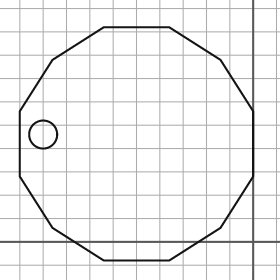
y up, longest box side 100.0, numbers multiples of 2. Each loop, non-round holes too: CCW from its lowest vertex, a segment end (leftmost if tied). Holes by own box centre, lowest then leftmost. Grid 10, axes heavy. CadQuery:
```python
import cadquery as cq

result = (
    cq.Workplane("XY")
    .moveTo(-64.0, -8.0)
    .lineTo(-36.0, -8.0)
    .lineTo(-14.0, 6.0)
    .lineTo(0.0, 28.0)
    .lineTo(0.0, 56.0)
    .lineTo(-14.0, 78.0)
    .lineTo(-36.0, 92.0)
    .lineTo(-64.0, 92.0)
    .lineTo(-86.0, 78.0)
    .lineTo(-100.0, 56.0)
    .lineTo(-100.0, 28.0)
    .lineTo(-86.0, 6.0)
    .close()
    .moveTo(-90.0, 46.0)
    .circle(6.0)
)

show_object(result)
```